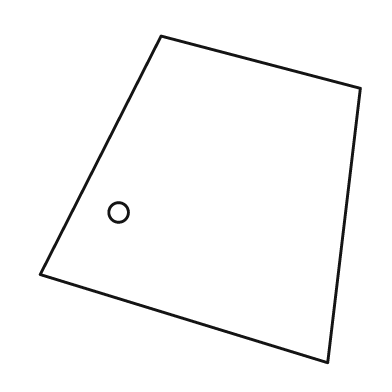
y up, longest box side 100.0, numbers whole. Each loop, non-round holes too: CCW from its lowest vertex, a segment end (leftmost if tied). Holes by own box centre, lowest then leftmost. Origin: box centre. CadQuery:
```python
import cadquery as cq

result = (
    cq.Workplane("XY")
    .moveTo(39.0, -50.0)
    .lineTo(49.0, 34.0)
    .lineTo(-12.0, 50.0)
    .lineTo(-49.0, -23.0)
    .close()
    .moveTo(-25.0, -4.0)
    .circle(3.0)
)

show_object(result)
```